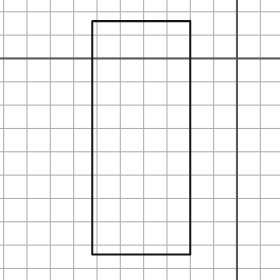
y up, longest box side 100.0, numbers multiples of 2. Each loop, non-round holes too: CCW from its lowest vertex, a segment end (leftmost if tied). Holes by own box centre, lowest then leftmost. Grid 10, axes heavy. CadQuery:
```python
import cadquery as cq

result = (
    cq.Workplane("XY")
    .moveTo(-62.0, -84.0)
    .lineTo(-20.0, -84.0)
    .lineTo(-20.0, 16.0)
    .lineTo(-62.0, 16.0)
    .close()
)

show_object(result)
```